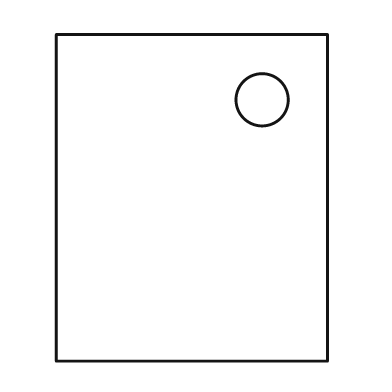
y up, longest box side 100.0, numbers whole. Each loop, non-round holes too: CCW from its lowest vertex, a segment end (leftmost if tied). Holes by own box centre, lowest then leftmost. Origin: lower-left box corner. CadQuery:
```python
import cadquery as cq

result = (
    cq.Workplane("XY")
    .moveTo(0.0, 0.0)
    .lineTo(83.0, 0.0)
    .lineTo(83.0, 100.0)
    .lineTo(0.0, 100.0)
    .close()
    .moveTo(63.0, 80.0)
    .circle(8.0)
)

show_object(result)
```